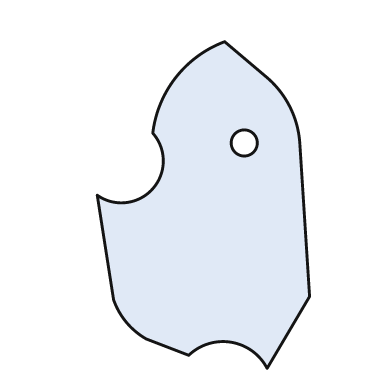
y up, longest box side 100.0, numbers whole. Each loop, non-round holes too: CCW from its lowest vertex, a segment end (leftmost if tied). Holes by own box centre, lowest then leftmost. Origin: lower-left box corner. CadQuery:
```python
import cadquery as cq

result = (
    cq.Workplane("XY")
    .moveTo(52.0, 0.0)
    .lineTo(65.0, 22.0)
    .lineTo(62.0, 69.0)
    .threePointArc((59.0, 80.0), (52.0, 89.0))
    .lineTo(39.0, 100.0)
    .threePointArc((24.0, 89.0), (17.0, 72.0))
    .threePointArc((17.0, 55.0), (0.0, 53.0))
    .lineTo(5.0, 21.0)
    .threePointArc((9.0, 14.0), (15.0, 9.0))
    .lineTo(28.0, 4.0)
    .threePointArc((41.0, 8.0), (52.0, 0.0))
    .close()
    .moveTo(45.0, 69.0)
    .circle(4.0)
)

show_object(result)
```